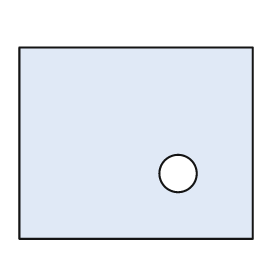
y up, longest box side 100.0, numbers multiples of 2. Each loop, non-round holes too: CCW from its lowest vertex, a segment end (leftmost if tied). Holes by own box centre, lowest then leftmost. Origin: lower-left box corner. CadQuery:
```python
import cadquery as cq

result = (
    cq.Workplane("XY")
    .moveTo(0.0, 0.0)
    .lineTo(100.0, 0.0)
    .lineTo(100.0, 82.0)
    .lineTo(0.0, 82.0)
    .close()
    .moveTo(68.0, 28.0)
    .circle(8.0)
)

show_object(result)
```